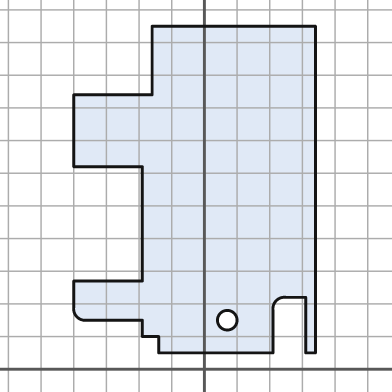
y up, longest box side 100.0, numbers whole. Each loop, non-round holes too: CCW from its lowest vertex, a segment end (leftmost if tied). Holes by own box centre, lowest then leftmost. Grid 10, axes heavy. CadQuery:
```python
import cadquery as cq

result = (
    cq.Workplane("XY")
    .moveTo(-14.0, 5.0)
    .lineTo(21.0, 5.0)
    .lineTo(21.0, 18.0)
    .threePointArc((22.0, 21.0), (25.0, 22.0))
    .lineTo(31.0, 22.0)
    .lineTo(31.0, 5.0)
    .lineTo(34.0, 5.0)
    .lineTo(34.0, 105.0)
    .lineTo(-16.0, 105.0)
    .lineTo(-16.0, 84.0)
    .lineTo(-40.0, 84.0)
    .lineTo(-40.0, 62.0)
    .lineTo(-19.0, 62.0)
    .lineTo(-19.0, 27.0)
    .lineTo(-40.0, 27.0)
    .lineTo(-40.0, 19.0)
    .threePointArc((-39.0, 16.0), (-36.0, 15.0))
    .lineTo(-19.0, 15.0)
    .lineTo(-19.0, 10.0)
    .lineTo(-14.0, 10.0)
    .close()
    .moveTo(7.0, 15.0)
    .circle(3.0)
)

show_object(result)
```